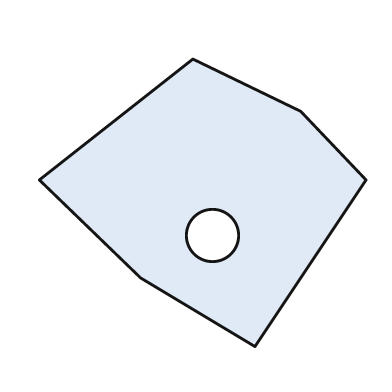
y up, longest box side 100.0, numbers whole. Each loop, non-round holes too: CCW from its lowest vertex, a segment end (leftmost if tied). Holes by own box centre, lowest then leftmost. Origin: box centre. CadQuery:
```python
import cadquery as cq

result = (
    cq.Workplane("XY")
    .moveTo(16.0, -44.0)
    .lineTo(50.0, 7.0)
    .lineTo(30.0, 28.0)
    .lineTo(-3.0, 44.0)
    .lineTo(-50.0, 7.0)
    .lineTo(-19.0, -23.0)
    .close()
    .moveTo(3.0, -10.0)
    .circle(8.0)
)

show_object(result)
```